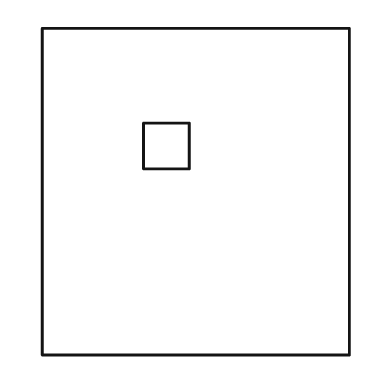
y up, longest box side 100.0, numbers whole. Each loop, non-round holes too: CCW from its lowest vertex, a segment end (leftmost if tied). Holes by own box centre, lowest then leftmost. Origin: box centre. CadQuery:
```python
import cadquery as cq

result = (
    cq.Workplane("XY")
    .moveTo(-47.0, -50.0)
    .lineTo(47.0, -50.0)
    .lineTo(47.0, 50.0)
    .lineTo(-47.0, 50.0)
    .close()
    .moveTo(-16.0, 7.0)
    .lineTo(-2.0, 7.0)
    .lineTo(-2.0, 21.0)
    .lineTo(-16.0, 21.0)
    .close()
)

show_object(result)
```